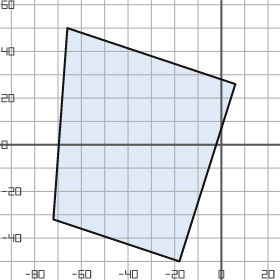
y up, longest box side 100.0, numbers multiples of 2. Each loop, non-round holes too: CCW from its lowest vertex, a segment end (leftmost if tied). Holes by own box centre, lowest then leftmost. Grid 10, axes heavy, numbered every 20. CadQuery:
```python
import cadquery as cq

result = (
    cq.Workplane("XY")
    .moveTo(-18.0, -50.0)
    .lineTo(6.0, 26.0)
    .lineTo(-66.0, 50.0)
    .lineTo(-72.0, -32.0)
    .close()
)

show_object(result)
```